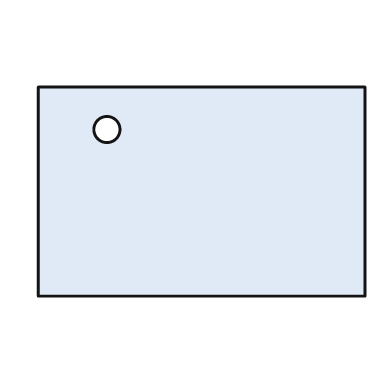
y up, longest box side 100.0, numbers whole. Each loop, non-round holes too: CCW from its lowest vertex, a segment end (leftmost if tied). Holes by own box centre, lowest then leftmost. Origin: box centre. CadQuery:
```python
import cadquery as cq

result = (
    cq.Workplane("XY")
    .moveTo(-50.0, -32.0)
    .lineTo(50.0, -32.0)
    .lineTo(50.0, 32.0)
    .lineTo(-50.0, 32.0)
    .close()
    .moveTo(-29.0, 19.0)
    .circle(4.0)
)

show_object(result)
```